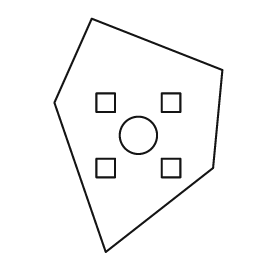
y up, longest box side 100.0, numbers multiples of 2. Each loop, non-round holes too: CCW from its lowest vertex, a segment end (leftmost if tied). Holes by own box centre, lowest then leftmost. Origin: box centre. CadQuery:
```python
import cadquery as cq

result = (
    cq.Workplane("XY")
    .moveTo(-14.0, -50.0)
    .lineTo(32.0, -14.0)
    .lineTo(36.0, 28.0)
    .lineTo(-20.0, 50.0)
    .lineTo(-36.0, 14.0)
    .close()
    .moveTo(-18.0, -18.0)
    .lineTo(-10.0, -18.0)
    .lineTo(-10.0, -10.0)
    .lineTo(-18.0, -10.0)
    .close()
    .moveTo(10.0, -18.0)
    .lineTo(18.0, -18.0)
    .lineTo(18.0, -10.0)
    .lineTo(10.0, -10.0)
    .close()
    .moveTo(0.0, 0.0)
    .circle(8.0)
    .moveTo(-18.0, 10.0)
    .lineTo(-10.0, 10.0)
    .lineTo(-10.0, 18.0)
    .lineTo(-18.0, 18.0)
    .close()
    .moveTo(10.0, 10.0)
    .lineTo(18.0, 10.0)
    .lineTo(18.0, 18.0)
    .lineTo(10.0, 18.0)
    .close()
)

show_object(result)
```